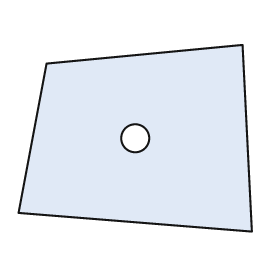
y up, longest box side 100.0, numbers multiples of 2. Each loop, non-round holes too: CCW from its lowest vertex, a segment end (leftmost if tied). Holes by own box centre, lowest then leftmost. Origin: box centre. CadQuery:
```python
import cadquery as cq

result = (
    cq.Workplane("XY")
    .moveTo(50.0, -40.0)
    .lineTo(46.0, 40.0)
    .lineTo(-38.0, 32.0)
    .lineTo(-50.0, -32.0)
    .close()
    .moveTo(0.0, 0.0)
    .circle(6.0)
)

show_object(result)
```